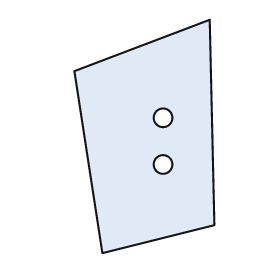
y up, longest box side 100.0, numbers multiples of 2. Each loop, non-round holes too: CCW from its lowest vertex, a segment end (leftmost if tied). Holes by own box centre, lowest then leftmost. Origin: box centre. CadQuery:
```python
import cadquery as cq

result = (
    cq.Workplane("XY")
    .moveTo(-18.0, -50.0)
    .lineTo(30.0, -38.0)
    .lineTo(28.0, 50.0)
    .lineTo(-30.0, 28.0)
    .close()
    .moveTo(8.0, -12.0)
    .circle(4.0)
    .moveTo(8.0, 8.0)
    .circle(4.0)
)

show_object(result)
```